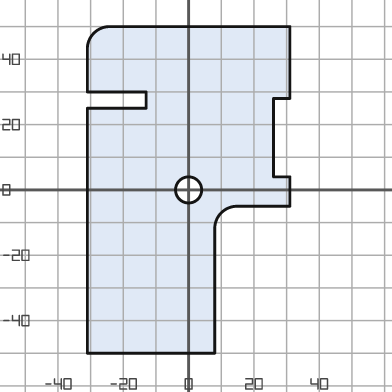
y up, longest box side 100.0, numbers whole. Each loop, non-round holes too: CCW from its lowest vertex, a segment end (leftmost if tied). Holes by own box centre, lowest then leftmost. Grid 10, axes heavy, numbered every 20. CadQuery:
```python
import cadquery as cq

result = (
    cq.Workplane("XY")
    .moveTo(-31.0, -50.0)
    .lineTo(8.0, -50.0)
    .lineTo(8.0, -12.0)
    .threePointArc((10.0, -7.0), (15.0, -5.0))
    .lineTo(31.0, -5.0)
    .lineTo(31.0, 4.0)
    .lineTo(26.0, 4.0)
    .lineTo(26.0, 28.0)
    .lineTo(31.0, 28.0)
    .lineTo(31.0, 50.0)
    .lineTo(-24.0, 50.0)
    .threePointArc((-29.0, 48.0), (-31.0, 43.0))
    .lineTo(-31.0, 30.0)
    .lineTo(-13.0, 30.0)
    .lineTo(-13.0, 25.0)
    .lineTo(-31.0, 25.0)
    .close()
    .moveTo(0.0, 0.0)
    .circle(4.0)
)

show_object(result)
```